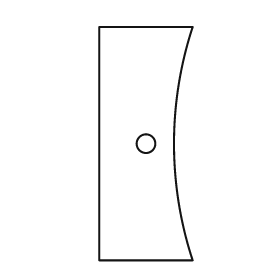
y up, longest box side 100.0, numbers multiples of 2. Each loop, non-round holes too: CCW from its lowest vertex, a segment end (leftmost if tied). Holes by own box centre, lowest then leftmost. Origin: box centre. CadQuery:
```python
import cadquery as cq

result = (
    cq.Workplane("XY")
    .moveTo(-20.0, -50.0)
    .lineTo(20.0, -50.0)
    .threePointArc((12.0, 0.0), (20.0, 50.0))
    .lineTo(-20.0, 50.0)
    .close()
    .moveTo(0.0, 0.0)
    .circle(4.0)
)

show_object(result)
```